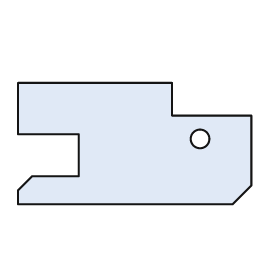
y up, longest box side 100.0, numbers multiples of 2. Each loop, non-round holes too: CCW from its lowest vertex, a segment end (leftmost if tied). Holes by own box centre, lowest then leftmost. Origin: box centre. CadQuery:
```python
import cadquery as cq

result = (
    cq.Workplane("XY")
    .moveTo(-50.0, -26.0)
    .lineTo(42.0, -26.0)
    .lineTo(50.0, -18.0)
    .lineTo(50.0, 12.0)
    .lineTo(16.0, 12.0)
    .lineTo(16.0, 26.0)
    .lineTo(-50.0, 26.0)
    .lineTo(-50.0, 4.0)
    .lineTo(-24.0, 4.0)
    .lineTo(-24.0, -14.0)
    .lineTo(-44.0, -14.0)
    .lineTo(-50.0, -20.0)
    .close()
    .moveTo(28.0, 2.0)
    .circle(4.0)
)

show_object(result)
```